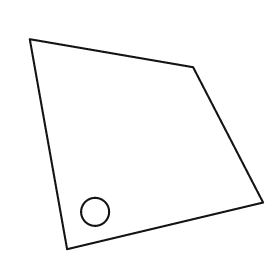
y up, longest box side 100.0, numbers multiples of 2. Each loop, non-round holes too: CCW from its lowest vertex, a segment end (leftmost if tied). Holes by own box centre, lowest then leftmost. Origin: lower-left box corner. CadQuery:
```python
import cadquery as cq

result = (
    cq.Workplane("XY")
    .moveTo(16.0, 0.0)
    .lineTo(100.0, 20.0)
    .lineTo(70.0, 78.0)
    .lineTo(0.0, 90.0)
    .close()
    .moveTo(28.0, 16.0)
    .circle(6.0)
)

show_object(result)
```